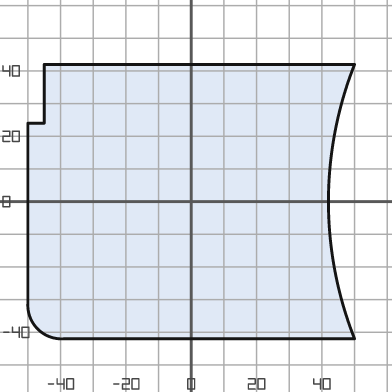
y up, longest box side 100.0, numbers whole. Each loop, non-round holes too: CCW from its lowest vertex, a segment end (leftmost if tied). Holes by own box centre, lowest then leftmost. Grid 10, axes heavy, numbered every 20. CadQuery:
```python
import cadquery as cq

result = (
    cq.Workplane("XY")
    .moveTo(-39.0, -42.0)
    .lineTo(50.0, -42.0)
    .threePointArc((42.0, 0.0), (50.0, 42.0))
    .lineTo(-45.0, 42.0)
    .lineTo(-45.0, 24.0)
    .lineTo(-50.0, 24.0)
    .lineTo(-50.0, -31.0)
    .threePointArc((-47.0, -39.0), (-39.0, -42.0))
    .close()
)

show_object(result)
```